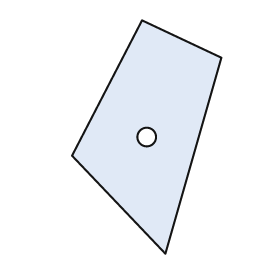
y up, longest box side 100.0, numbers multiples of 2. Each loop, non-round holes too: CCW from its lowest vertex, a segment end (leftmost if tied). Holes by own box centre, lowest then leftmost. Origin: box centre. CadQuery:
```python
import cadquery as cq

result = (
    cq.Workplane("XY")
    .moveTo(8.0, -50.0)
    .lineTo(32.0, 34.0)
    .lineTo(-2.0, 50.0)
    .lineTo(-32.0, -8.0)
    .close()
    .moveTo(0.0, 0.0)
    .circle(4.0)
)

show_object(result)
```